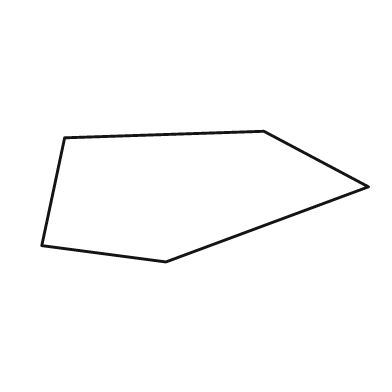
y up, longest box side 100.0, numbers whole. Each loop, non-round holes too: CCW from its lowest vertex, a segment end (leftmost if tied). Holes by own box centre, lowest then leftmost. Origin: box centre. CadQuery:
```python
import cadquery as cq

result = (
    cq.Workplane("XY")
    .moveTo(-12.0, -20.0)
    .lineTo(50.0, 3.0)
    .lineTo(18.0, 20.0)
    .lineTo(-43.0, 18.0)
    .lineTo(-50.0, -15.0)
    .close()
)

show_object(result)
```